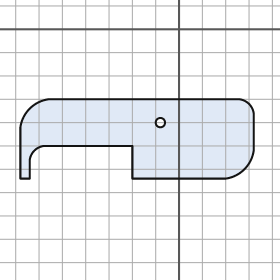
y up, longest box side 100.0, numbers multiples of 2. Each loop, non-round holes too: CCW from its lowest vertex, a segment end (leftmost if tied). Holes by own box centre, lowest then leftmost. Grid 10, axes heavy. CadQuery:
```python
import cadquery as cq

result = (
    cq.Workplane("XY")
    .moveTo(-68.0, -64.0)
    .lineTo(-64.0, -64.0)
    .lineTo(-64.0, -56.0)
    .threePointArc((-62.0, -52.0), (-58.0, -50.0))
    .lineTo(-20.0, -50.0)
    .lineTo(-20.0, -64.0)
    .lineTo(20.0, -64.0)
    .threePointArc((28.0, -60.0), (32.0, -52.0))
    .lineTo(32.0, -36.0)
    .threePointArc((30.0, -32.0), (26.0, -30.0))
    .lineTo(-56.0, -30.0)
    .threePointArc((-64.0, -34.0), (-68.0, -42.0))
    .close()
    .moveTo(-8.0, -40.0)
    .circle(2.0)
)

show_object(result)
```